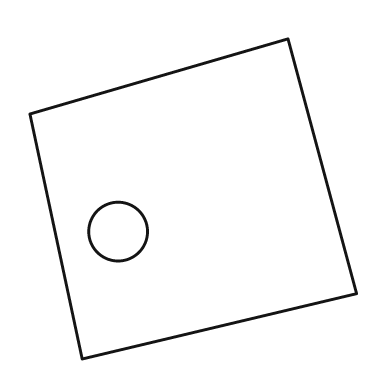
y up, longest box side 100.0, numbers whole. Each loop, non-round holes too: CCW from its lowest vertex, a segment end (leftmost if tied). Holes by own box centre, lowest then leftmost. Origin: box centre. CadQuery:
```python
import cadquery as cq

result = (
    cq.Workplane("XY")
    .moveTo(-34.0, -49.0)
    .lineTo(50.0, -29.0)
    .lineTo(29.0, 49.0)
    .lineTo(-50.0, 26.0)
    .close()
    .moveTo(-23.0, -10.0)
    .circle(9.0)
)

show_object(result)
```